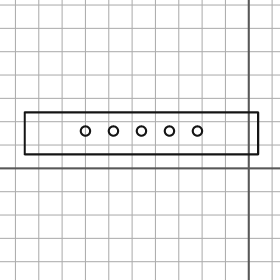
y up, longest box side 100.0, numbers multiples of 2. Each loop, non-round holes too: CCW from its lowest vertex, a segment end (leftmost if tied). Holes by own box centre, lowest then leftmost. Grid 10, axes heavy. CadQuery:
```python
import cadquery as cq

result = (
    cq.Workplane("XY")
    .moveTo(-96.0, 6.0)
    .lineTo(4.0, 6.0)
    .lineTo(4.0, 24.0)
    .lineTo(-96.0, 24.0)
    .close()
    .moveTo(-70.0, 16.0)
    .circle(2.0)
    .moveTo(-58.0, 16.0)
    .circle(2.0)
    .moveTo(-46.0, 16.0)
    .circle(2.0)
    .moveTo(-34.0, 16.0)
    .circle(2.0)
    .moveTo(-22.0, 16.0)
    .circle(2.0)
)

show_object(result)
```